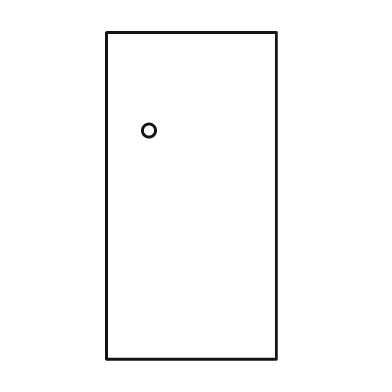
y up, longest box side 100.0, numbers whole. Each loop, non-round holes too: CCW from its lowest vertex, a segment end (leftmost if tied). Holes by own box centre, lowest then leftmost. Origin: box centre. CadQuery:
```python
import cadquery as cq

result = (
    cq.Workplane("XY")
    .moveTo(-26.0, -50.0)
    .lineTo(26.0, -50.0)
    .lineTo(26.0, 50.0)
    .lineTo(-26.0, 50.0)
    .close()
    .moveTo(-13.0, 20.0)
    .circle(2.0)
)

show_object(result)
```